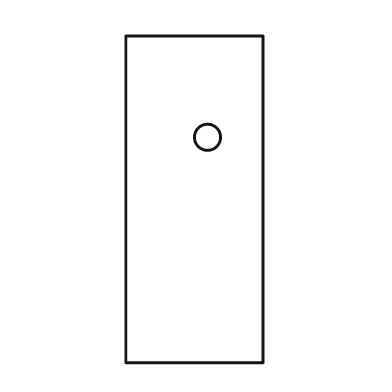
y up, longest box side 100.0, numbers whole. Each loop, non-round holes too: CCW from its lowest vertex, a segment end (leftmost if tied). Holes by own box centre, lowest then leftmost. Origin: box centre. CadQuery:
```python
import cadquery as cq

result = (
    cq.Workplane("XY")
    .moveTo(-21.0, -50.0)
    .lineTo(21.0, -50.0)
    .lineTo(21.0, 50.0)
    .lineTo(-21.0, 50.0)
    .close()
    .moveTo(4.0, 19.0)
    .circle(4.0)
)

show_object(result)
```